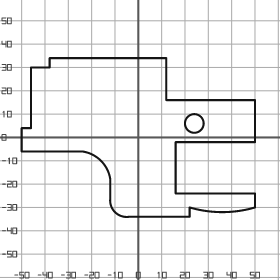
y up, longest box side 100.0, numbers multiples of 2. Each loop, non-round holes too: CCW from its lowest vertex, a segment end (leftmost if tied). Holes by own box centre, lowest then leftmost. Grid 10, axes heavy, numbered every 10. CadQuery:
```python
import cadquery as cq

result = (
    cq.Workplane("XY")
    .moveTo(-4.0, -34.0)
    .lineTo(22.0, -34.0)
    .lineTo(22.0, -30.0)
    .threePointArc((36.0, -32.0), (50.0, -30.0))
    .lineTo(50.0, -24.0)
    .lineTo(16.0, -24.0)
    .lineTo(16.0, -2.0)
    .lineTo(50.0, -2.0)
    .lineTo(50.0, 16.0)
    .lineTo(12.0, 16.0)
    .lineTo(12.0, 34.0)
    .lineTo(-38.0, 34.0)
    .lineTo(-38.0, 30.0)
    .lineTo(-46.0, 30.0)
    .lineTo(-46.0, 4.0)
    .lineTo(-50.0, 4.0)
    .lineTo(-50.0, -6.0)
    .lineTo(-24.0, -6.0)
    .threePointArc((-16.0, -10.0), (-12.0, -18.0))
    .lineTo(-12.0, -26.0)
    .threePointArc((-10.0, -32.0), (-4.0, -34.0))
    .close()
    .moveTo(24.0, 6.0)
    .circle(4.0)
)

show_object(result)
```